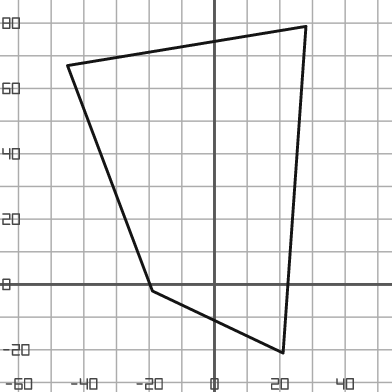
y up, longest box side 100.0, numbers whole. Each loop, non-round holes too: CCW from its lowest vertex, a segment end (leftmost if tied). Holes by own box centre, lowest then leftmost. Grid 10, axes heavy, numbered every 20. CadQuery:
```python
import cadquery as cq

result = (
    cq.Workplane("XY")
    .moveTo(21.0, -21.0)
    .lineTo(28.0, 79.0)
    .lineTo(-45.0, 67.0)
    .lineTo(-19.0, -2.0)
    .close()
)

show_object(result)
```